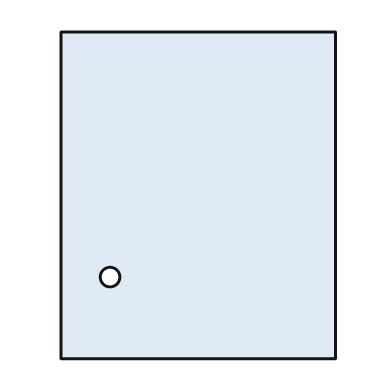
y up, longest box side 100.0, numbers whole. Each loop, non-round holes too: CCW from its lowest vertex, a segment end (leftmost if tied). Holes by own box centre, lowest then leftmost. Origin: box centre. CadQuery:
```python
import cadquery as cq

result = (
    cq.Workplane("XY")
    .moveTo(-42.0, -50.0)
    .lineTo(42.0, -50.0)
    .lineTo(42.0, 50.0)
    .lineTo(-42.0, 50.0)
    .close()
    .moveTo(-27.0, -25.0)
    .circle(3.0)
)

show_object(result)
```